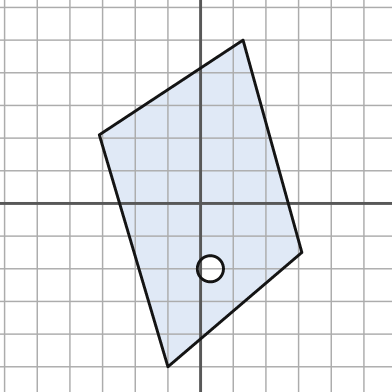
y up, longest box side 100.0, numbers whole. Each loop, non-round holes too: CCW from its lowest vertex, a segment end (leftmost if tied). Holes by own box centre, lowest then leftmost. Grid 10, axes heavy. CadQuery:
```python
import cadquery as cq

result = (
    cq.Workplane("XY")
    .moveTo(-10.0, -50.0)
    .lineTo(31.0, -15.0)
    .lineTo(13.0, 50.0)
    .lineTo(-31.0, 21.0)
    .close()
    .moveTo(3.0, -20.0)
    .circle(4.0)
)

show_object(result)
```